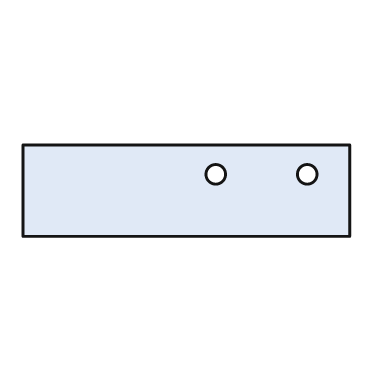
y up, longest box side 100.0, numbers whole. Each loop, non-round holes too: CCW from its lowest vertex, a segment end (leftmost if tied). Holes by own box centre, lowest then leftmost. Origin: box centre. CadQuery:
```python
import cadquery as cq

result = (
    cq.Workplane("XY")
    .moveTo(-50.0, -14.0)
    .lineTo(50.0, -14.0)
    .lineTo(50.0, 14.0)
    .lineTo(-50.0, 14.0)
    .close()
    .moveTo(9.0, 5.0)
    .circle(3.0)
    .moveTo(37.0, 5.0)
    .circle(3.0)
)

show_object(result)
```